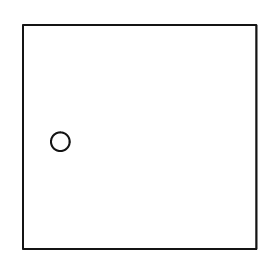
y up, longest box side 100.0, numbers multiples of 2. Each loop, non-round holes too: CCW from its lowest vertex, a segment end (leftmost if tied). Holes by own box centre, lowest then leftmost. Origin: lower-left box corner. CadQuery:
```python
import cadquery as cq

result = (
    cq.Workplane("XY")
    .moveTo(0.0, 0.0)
    .lineTo(100.0, 0.0)
    .lineTo(100.0, 96.0)
    .lineTo(0.0, 96.0)
    .close()
    .moveTo(16.0, 46.0)
    .circle(4.0)
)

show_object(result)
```